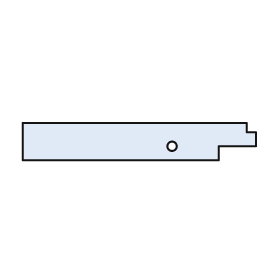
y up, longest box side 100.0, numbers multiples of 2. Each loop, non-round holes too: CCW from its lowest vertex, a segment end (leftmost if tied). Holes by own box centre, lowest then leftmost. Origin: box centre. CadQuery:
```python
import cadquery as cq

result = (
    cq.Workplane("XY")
    .moveTo(-50.0, -8.0)
    .lineTo(34.0, -8.0)
    .lineTo(34.0, -2.0)
    .lineTo(50.0, -2.0)
    .lineTo(50.0, 4.0)
    .lineTo(46.0, 4.0)
    .lineTo(46.0, 8.0)
    .lineTo(-50.0, 8.0)
    .close()
    .moveTo(14.0, -2.0)
    .circle(2.0)
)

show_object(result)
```